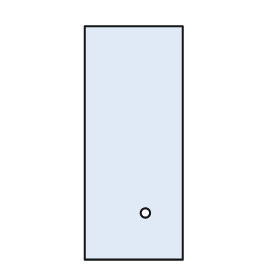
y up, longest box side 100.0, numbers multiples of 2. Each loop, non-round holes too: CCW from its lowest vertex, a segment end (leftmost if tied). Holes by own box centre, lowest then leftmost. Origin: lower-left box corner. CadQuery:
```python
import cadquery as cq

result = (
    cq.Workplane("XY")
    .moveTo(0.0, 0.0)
    .lineTo(42.0, 0.0)
    .lineTo(42.0, 100.0)
    .lineTo(0.0, 100.0)
    .close()
    .moveTo(26.0, 20.0)
    .circle(2.0)
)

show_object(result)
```